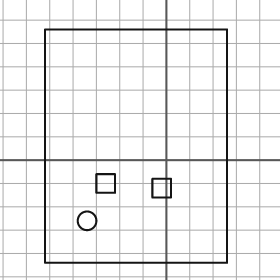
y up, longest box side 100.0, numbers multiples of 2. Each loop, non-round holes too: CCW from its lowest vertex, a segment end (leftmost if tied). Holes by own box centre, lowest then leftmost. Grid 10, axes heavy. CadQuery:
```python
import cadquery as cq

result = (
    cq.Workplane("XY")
    .moveTo(-52.0, -44.0)
    .lineTo(26.0, -44.0)
    .lineTo(26.0, 56.0)
    .lineTo(-52.0, 56.0)
    .close()
    .moveTo(-34.0, -26.0)
    .circle(4.0)
    .moveTo(-6.0, -16.0)
    .lineTo(2.0, -16.0)
    .lineTo(2.0, -8.0)
    .lineTo(-6.0, -8.0)
    .close()
    .moveTo(-30.0, -14.0)
    .lineTo(-22.0, -14.0)
    .lineTo(-22.0, -6.0)
    .lineTo(-30.0, -6.0)
    .close()
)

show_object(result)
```